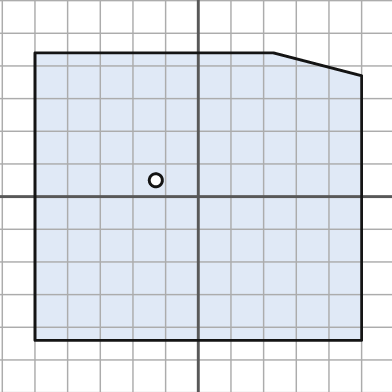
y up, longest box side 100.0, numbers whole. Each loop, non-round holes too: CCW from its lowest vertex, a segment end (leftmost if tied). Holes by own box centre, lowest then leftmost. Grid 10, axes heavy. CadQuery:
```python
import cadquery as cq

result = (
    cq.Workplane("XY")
    .moveTo(-50.0, -44.0)
    .lineTo(50.0, -44.0)
    .lineTo(50.0, 37.0)
    .lineTo(23.0, 44.0)
    .lineTo(-50.0, 44.0)
    .close()
    .moveTo(-13.0, 5.0)
    .circle(2.0)
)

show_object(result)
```